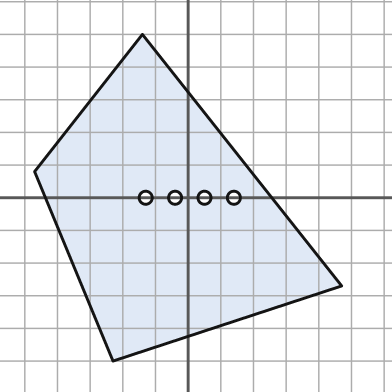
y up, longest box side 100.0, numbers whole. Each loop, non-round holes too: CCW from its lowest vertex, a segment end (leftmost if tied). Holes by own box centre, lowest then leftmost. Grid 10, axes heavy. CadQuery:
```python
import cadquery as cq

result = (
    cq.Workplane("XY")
    .moveTo(-23.0, -50.0)
    .lineTo(47.0, -27.0)
    .lineTo(-14.0, 50.0)
    .lineTo(-47.0, 8.0)
    .close()
    .moveTo(-13.0, 0.0)
    .circle(2.0)
    .moveTo(-4.0, 0.0)
    .circle(2.0)
    .moveTo(5.0, 0.0)
    .circle(2.0)
    .moveTo(14.0, 0.0)
    .circle(2.0)
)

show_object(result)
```